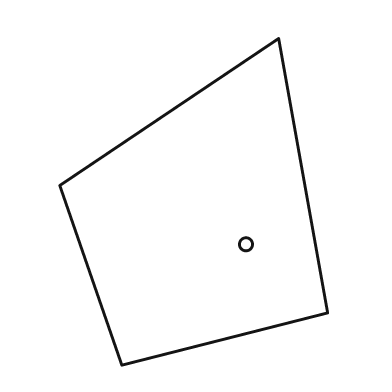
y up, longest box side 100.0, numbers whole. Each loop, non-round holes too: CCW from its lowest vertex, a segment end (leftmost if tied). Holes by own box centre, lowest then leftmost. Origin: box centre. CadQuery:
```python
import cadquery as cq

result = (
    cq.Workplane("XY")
    .moveTo(-22.0, -50.0)
    .lineTo(41.0, -34.0)
    .lineTo(26.0, 50.0)
    .lineTo(-41.0, 5.0)
    .close()
    .moveTo(16.0, -13.0)
    .circle(2.0)
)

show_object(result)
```